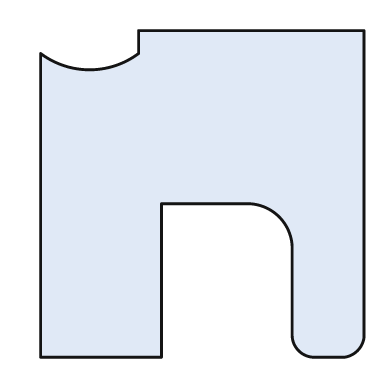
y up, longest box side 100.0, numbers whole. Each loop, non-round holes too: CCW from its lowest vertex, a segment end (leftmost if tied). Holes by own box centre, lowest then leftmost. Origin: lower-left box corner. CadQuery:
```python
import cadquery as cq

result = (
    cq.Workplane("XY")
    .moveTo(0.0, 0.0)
    .lineTo(37.0, 0.0)
    .lineTo(37.0, 47.0)
    .lineTo(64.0, 47.0)
    .threePointArc((73.0, 43.0), (77.0, 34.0))
    .lineTo(77.0, 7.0)
    .threePointArc((79.0, 2.0), (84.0, 0.0))
    .lineTo(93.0, 0.0)
    .threePointArc((97.0, 2.0), (99.0, 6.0))
    .lineTo(99.0, 100.0)
    .lineTo(30.0, 100.0)
    .lineTo(30.0, 93.0)
    .threePointArc((15.0, 88.0), (0.0, 93.0))
    .close()
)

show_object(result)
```